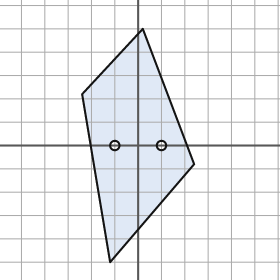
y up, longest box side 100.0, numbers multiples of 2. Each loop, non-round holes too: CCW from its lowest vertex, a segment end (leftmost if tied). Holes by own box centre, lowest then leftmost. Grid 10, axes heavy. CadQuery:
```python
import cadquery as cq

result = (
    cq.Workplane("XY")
    .moveTo(-12.0, -50.0)
    .lineTo(24.0, -8.0)
    .lineTo(2.0, 50.0)
    .lineTo(-24.0, 22.0)
    .close()
    .moveTo(-10.0, 0.0)
    .circle(2.0)
    .moveTo(10.0, 0.0)
    .circle(2.0)
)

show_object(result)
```